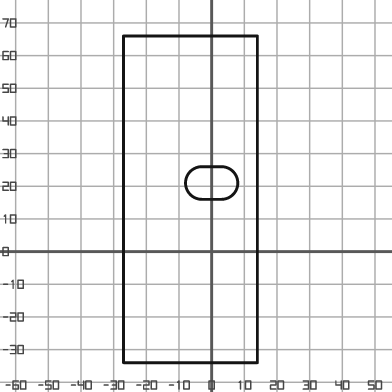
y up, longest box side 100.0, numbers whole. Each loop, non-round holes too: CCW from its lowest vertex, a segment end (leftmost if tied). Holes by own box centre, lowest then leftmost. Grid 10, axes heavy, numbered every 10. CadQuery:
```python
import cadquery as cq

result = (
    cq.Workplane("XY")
    .moveTo(-27.0, -34.0)
    .lineTo(14.0, -34.0)
    .lineTo(14.0, 66.0)
    .lineTo(-27.0, 66.0)
    .close()
    .moveTo(-3.0, 16.0)
    .lineTo(3.0, 16.0)
    .threePointArc((8.0, 21.0), (3.0, 26.0))
    .lineTo(-3.0, 26.0)
    .threePointArc((-8.0, 21.0), (-3.0, 16.0))
    .close()
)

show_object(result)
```